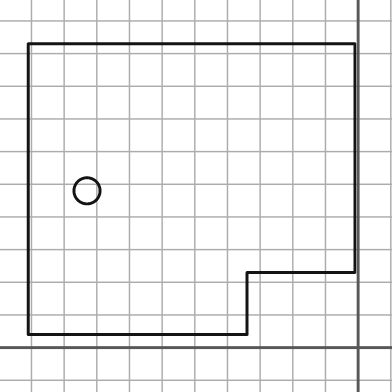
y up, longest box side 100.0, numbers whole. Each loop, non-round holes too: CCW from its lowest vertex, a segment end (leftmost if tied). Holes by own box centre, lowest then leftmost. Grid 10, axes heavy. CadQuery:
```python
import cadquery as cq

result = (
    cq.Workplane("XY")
    .moveTo(-101.0, 4.0)
    .lineTo(-34.0, 4.0)
    .lineTo(-34.0, 23.0)
    .lineTo(-1.0, 23.0)
    .lineTo(-1.0, 93.0)
    .lineTo(-101.0, 93.0)
    .close()
    .moveTo(-83.0, 48.0)
    .circle(4.0)
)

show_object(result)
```